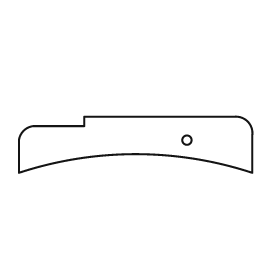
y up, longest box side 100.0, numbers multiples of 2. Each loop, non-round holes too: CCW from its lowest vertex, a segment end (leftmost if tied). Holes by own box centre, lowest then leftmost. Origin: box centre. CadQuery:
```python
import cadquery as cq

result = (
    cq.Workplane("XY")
    .moveTo(-50.0, -12.0)
    .threePointArc((0.0, -4.0), (50.0, -12.0))
    .lineTo(50.0, 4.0)
    .threePointArc((48.0, 10.0), (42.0, 12.0))
    .lineTo(-22.0, 12.0)
    .lineTo(-22.0, 8.0)
    .lineTo(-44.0, 8.0)
    .threePointArc((-48.0, 6.0), (-50.0, 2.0))
    .close()
    .moveTo(22.0, 2.0)
    .circle(2.0)
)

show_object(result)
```